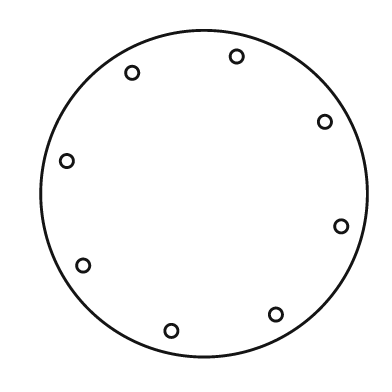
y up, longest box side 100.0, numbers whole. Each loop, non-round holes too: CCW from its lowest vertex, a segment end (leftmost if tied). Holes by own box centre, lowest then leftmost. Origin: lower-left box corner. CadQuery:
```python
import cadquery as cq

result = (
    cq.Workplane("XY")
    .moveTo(50.0, 50.0)
    .circle(50.0)
    .moveTo(40.0, 8.0)
    .circle(2.0)
    .moveTo(72.0, 13.0)
    .circle(2.0)
    .moveTo(13.0, 28.0)
    .circle(2.0)
    .moveTo(92.0, 40.0)
    .circle(2.0)
    .moveTo(8.0, 60.0)
    .circle(2.0)
    .moveTo(87.0, 72.0)
    .circle(2.0)
    .moveTo(28.0, 87.0)
    .circle(2.0)
    .moveTo(60.0, 92.0)
    .circle(2.0)
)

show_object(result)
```